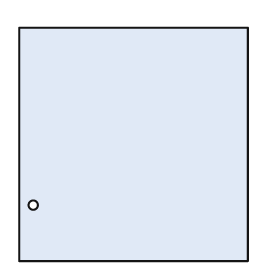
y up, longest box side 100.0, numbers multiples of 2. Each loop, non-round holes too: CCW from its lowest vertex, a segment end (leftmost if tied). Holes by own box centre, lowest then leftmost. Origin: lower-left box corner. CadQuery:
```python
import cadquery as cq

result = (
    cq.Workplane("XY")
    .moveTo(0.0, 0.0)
    .lineTo(98.0, 0.0)
    .lineTo(98.0, 100.0)
    .lineTo(0.0, 100.0)
    .close()
    .moveTo(6.0, 24.0)
    .circle(2.0)
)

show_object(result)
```